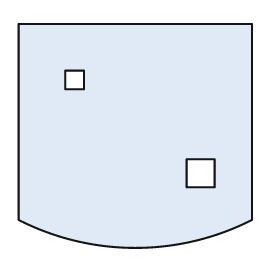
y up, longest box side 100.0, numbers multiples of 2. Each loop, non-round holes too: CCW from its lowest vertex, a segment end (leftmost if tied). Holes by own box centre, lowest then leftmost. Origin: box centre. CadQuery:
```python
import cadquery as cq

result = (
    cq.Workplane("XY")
    .moveTo(-50.0, -36.0)
    .threePointArc((0.0, -48.0), (50.0, -36.0))
    .lineTo(50.0, 48.0)
    .lineTo(-50.0, 48.0)
    .close()
    .moveTo(22.0, -22.0)
    .lineTo(34.0, -22.0)
    .lineTo(34.0, -10.0)
    .lineTo(22.0, -10.0)
    .close()
    .moveTo(-30.0, 20.0)
    .lineTo(-22.0, 20.0)
    .lineTo(-22.0, 28.0)
    .lineTo(-30.0, 28.0)
    .close()
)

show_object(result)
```